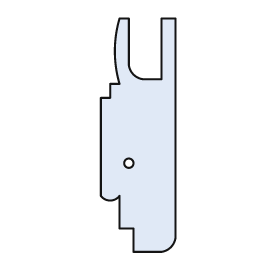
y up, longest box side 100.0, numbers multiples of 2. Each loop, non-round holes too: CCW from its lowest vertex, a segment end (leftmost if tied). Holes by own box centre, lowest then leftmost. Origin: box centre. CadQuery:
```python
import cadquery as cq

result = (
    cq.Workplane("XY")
    .moveTo(-2.0, -50.0)
    .lineTo(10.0, -50.0)
    .threePointArc((14.0, -48.0), (16.0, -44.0))
    .lineTo(16.0, 50.0)
    .lineTo(10.0, 50.0)
    .lineTo(10.0, 24.0)
    .lineTo(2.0, 24.0)
    .threePointArc((-2.0, 26.0), (-4.0, 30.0))
    .lineTo(-4.0, 50.0)
    .lineTo(-8.0, 50.0)
    .threePointArc((-10.0, 36.0), (-8.0, 22.0))
    .lineTo(-12.0, 22.0)
    .lineTo(-12.0, 16.0)
    .lineTo(-16.0, 16.0)
    .lineTo(-16.0, -26.0)
    .threePointArc((-12.0, -28.0), (-8.0, -26.0))
    .lineTo(-8.0, -40.0)
    .lineTo(-2.0, -40.0)
    .close()
    .moveTo(-4.0, -12.0)
    .circle(2.0)
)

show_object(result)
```